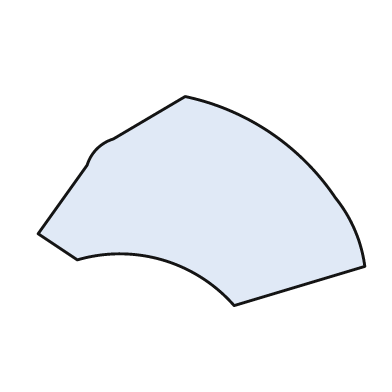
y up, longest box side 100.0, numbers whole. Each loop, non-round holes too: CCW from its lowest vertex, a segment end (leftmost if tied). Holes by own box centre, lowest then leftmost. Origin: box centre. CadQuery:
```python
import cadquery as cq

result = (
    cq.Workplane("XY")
    .moveTo(10.0, -32.0)
    .lineTo(50.0, -20.0)
    .threePointArc((47.0, -9.0), (41.0, 1.0))
    .threePointArc((21.0, 21.0), (-5.0, 32.0))
    .lineTo(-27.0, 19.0)
    .threePointArc((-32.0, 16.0), (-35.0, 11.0))
    .lineTo(-50.0, -10.0)
    .lineTo(-38.0, -18.0)
    .threePointArc((-12.0, -18.0), (10.0, -32.0))
    .close()
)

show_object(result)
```